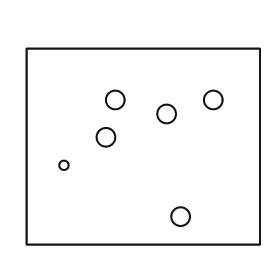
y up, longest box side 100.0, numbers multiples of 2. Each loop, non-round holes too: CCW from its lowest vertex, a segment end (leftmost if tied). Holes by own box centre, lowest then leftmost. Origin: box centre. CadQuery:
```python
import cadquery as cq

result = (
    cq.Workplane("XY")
    .moveTo(-50.0, -42.0)
    .lineTo(50.0, -42.0)
    .lineTo(50.0, 42.0)
    .lineTo(-50.0, 42.0)
    .close()
    .moveTo(16.0, -30.0)
    .circle(4.0)
    .moveTo(-34.0, -8.0)
    .circle(2.0)
    .moveTo(-16.0, 4.0)
    .circle(4.0)
    .moveTo(10.0, 14.0)
    .circle(4.0)
    .moveTo(-12.0, 20.0)
    .circle(4.0)
    .moveTo(30.0, 20.0)
    .circle(4.0)
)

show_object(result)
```